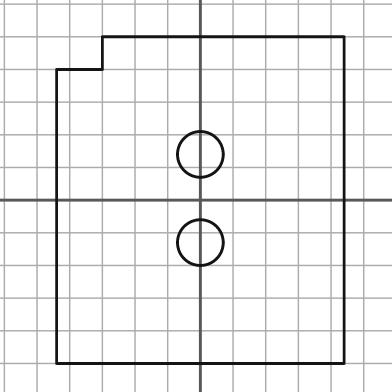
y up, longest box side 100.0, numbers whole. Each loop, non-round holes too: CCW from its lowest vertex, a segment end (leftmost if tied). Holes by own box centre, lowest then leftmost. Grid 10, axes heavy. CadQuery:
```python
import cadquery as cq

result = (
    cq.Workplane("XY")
    .moveTo(-44.0, -50.0)
    .lineTo(44.0, -50.0)
    .lineTo(44.0, 50.0)
    .lineTo(-30.0, 50.0)
    .lineTo(-30.0, 40.0)
    .lineTo(-44.0, 40.0)
    .close()
    .moveTo(0.0, -13.0)
    .circle(7.0)
    .moveTo(0.0, 14.0)
    .circle(7.0)
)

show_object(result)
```